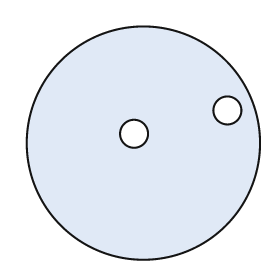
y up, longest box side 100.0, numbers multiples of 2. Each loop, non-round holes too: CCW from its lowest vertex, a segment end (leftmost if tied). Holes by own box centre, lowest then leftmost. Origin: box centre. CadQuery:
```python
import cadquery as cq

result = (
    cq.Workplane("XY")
    .moveTo(0.0, 0.0)
    .circle(50.0)
    .moveTo(-4.0, 4.0)
    .circle(6.0)
    .moveTo(36.0, 14.0)
    .circle(6.0)
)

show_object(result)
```